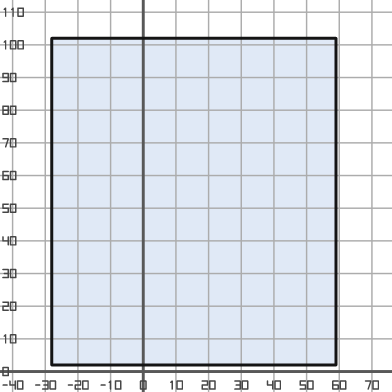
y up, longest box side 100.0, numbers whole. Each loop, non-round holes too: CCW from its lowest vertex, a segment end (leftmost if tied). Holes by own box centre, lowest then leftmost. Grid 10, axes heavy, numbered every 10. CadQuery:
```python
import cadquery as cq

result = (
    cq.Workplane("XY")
    .moveTo(-28.0, 2.0)
    .lineTo(59.0, 2.0)
    .lineTo(59.0, 102.0)
    .lineTo(-28.0, 102.0)
    .close()
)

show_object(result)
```